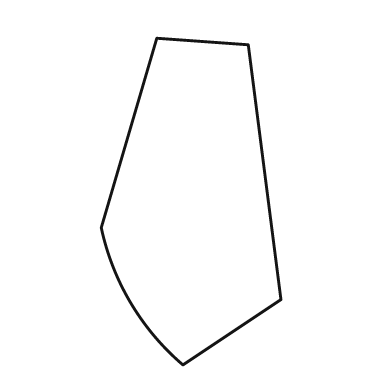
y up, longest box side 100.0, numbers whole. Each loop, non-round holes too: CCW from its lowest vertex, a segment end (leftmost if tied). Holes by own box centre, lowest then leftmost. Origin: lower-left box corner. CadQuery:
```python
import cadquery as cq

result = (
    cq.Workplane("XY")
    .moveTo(25.0, 0.0)
    .lineTo(55.0, 20.0)
    .lineTo(45.0, 98.0)
    .lineTo(17.0, 100.0)
    .lineTo(0.0, 42.0)
    .threePointArc((9.0, 19.0), (25.0, 0.0))
    .close()
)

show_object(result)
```